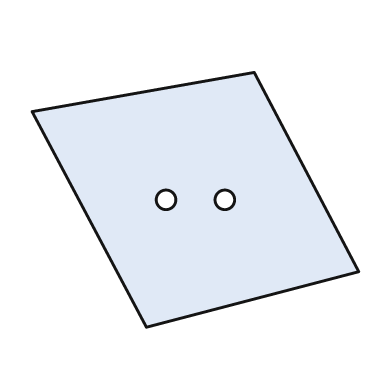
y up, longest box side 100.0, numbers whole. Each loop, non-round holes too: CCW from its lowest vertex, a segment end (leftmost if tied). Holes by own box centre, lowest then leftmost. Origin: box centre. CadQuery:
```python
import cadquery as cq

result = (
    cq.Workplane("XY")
    .moveTo(-15.0, -39.0)
    .lineTo(50.0, -22.0)
    .lineTo(18.0, 39.0)
    .lineTo(-50.0, 27.0)
    .close()
    .moveTo(-9.0, 0.0)
    .circle(3.0)
    .moveTo(9.0, 0.0)
    .circle(3.0)
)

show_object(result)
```